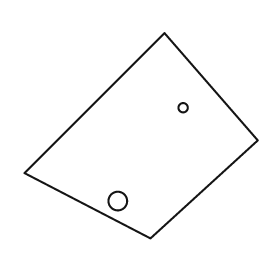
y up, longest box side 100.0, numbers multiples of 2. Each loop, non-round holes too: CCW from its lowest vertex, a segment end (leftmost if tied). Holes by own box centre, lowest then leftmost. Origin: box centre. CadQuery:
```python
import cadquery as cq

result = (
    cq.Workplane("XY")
    .moveTo(4.0, -44.0)
    .lineTo(50.0, -2.0)
    .lineTo(10.0, 44.0)
    .lineTo(-50.0, -16.0)
    .close()
    .moveTo(-10.0, -28.0)
    .circle(4.0)
    .moveTo(18.0, 12.0)
    .circle(2.0)
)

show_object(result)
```